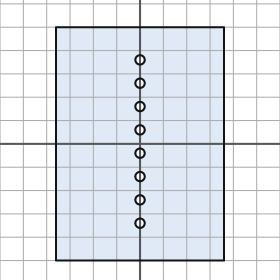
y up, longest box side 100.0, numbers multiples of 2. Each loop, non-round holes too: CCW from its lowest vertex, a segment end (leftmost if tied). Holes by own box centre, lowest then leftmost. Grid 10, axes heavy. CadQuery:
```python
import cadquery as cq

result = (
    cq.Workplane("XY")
    .moveTo(-36.0, -50.0)
    .lineTo(36.0, -50.0)
    .lineTo(36.0, 50.0)
    .lineTo(-36.0, 50.0)
    .close()
    .moveTo(0.0, -34.0)
    .circle(2.0)
    .moveTo(0.0, -24.0)
    .circle(2.0)
    .moveTo(0.0, -14.0)
    .circle(2.0)
    .moveTo(0.0, -4.0)
    .circle(2.0)
    .moveTo(0.0, 6.0)
    .circle(2.0)
    .moveTo(0.0, 16.0)
    .circle(2.0)
    .moveTo(0.0, 26.0)
    .circle(2.0)
    .moveTo(0.0, 36.0)
    .circle(2.0)
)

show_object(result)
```